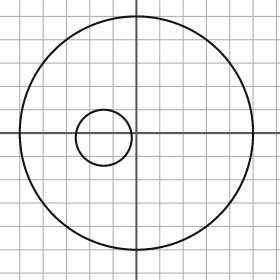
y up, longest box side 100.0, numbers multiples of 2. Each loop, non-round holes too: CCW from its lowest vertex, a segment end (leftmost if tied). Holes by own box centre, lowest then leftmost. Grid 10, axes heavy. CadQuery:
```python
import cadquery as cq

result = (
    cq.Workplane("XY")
    .moveTo(0.0, 0.0)
    .circle(50.0)
    .moveTo(-14.0, -2.0)
    .circle(12.0)
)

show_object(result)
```